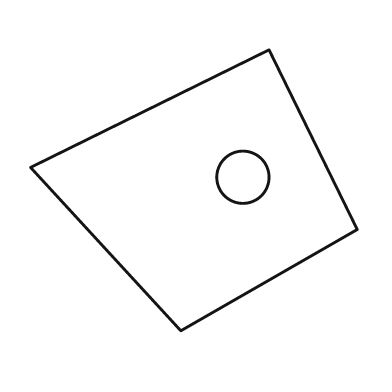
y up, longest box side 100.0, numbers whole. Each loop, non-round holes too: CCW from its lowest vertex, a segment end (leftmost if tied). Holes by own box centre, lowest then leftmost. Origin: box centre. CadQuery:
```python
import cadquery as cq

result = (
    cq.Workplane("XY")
    .moveTo(-4.0, -43.0)
    .lineTo(50.0, -12.0)
    .lineTo(23.0, 43.0)
    .lineTo(-50.0, 7.0)
    .close()
    .moveTo(15.0, 4.0)
    .circle(8.0)
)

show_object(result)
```